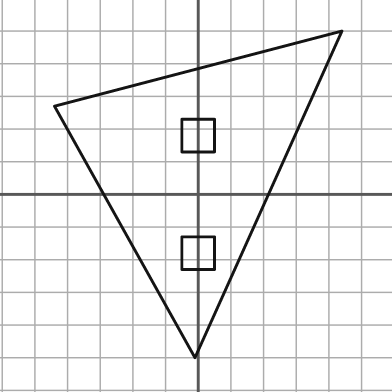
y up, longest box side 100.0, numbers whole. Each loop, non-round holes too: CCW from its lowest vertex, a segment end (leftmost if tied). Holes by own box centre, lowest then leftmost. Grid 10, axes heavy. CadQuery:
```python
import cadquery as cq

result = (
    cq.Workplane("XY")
    .moveTo(-1.0, -50.0)
    .lineTo(44.0, 50.0)
    .lineTo(-44.0, 27.0)
    .close()
    .moveTo(-5.0, -23.0)
    .lineTo(5.0, -23.0)
    .lineTo(5.0, -13.0)
    .lineTo(-5.0, -13.0)
    .close()
    .moveTo(-5.0, 13.0)
    .lineTo(5.0, 13.0)
    .lineTo(5.0, 23.0)
    .lineTo(-5.0, 23.0)
    .close()
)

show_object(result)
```